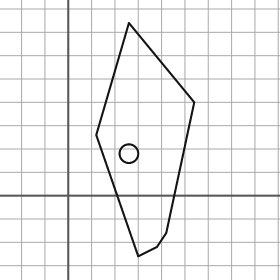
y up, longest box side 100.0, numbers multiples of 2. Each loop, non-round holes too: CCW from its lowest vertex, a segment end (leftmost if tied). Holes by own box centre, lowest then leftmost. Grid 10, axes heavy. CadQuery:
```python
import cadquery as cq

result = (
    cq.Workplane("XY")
    .moveTo(30.0, -26.0)
    .lineTo(38.0, -22.0)
    .lineTo(42.0, -16.0)
    .lineTo(54.0, 40.0)
    .lineTo(26.0, 74.0)
    .lineTo(12.0, 26.0)
    .close()
    .moveTo(26.0, 18.0)
    .circle(4.0)
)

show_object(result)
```